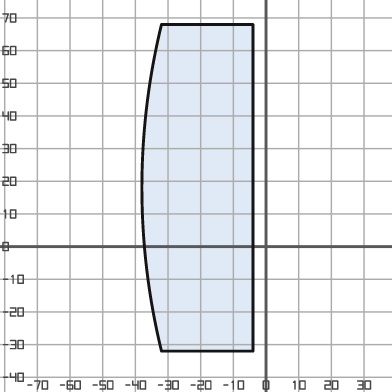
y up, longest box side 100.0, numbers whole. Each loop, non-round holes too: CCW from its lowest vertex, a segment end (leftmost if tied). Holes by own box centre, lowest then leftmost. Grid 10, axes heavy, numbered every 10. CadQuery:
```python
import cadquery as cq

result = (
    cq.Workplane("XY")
    .moveTo(-32.0, -32.0)
    .lineTo(-4.0, -32.0)
    .lineTo(-4.0, 68.0)
    .lineTo(-32.0, 68.0)
    .threePointArc((-38.0, 18.0), (-32.0, -32.0))
    .close()
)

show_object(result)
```